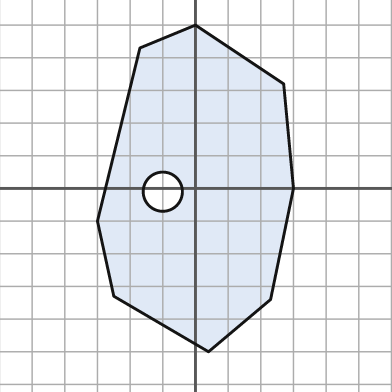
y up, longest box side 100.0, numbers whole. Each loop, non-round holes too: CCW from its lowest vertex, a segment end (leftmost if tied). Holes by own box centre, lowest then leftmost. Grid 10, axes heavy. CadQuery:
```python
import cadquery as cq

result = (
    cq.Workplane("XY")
    .moveTo(4.0, -50.0)
    .lineTo(23.0, -34.0)
    .lineTo(30.0, 0.0)
    .lineTo(27.0, 32.0)
    .lineTo(0.0, 50.0)
    .lineTo(-17.0, 43.0)
    .lineTo(-30.0, -10.0)
    .lineTo(-25.0, -33.0)
    .close()
    .moveTo(-10.0, -1.0)
    .circle(6.0)
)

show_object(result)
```